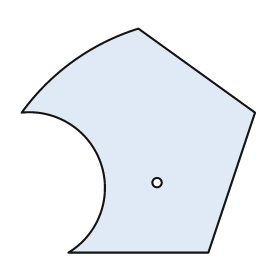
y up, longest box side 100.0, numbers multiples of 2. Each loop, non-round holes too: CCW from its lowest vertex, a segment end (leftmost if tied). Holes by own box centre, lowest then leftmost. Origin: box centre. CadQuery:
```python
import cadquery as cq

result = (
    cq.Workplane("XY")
    .moveTo(-30.0, -48.0)
    .lineTo(30.0, -48.0)
    .lineTo(50.0, 12.0)
    .lineTo(0.0, 48.0)
    .threePointArc((-28.0, 34.0), (-50.0, 12.0))
    .threePointArc((-16.0, -10.0), (-30.0, -48.0))
    .close()
    .moveTo(8.0, -18.0)
    .circle(2.0)
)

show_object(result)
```